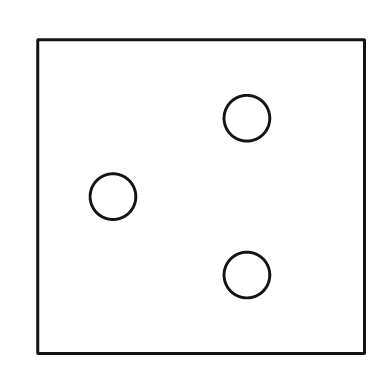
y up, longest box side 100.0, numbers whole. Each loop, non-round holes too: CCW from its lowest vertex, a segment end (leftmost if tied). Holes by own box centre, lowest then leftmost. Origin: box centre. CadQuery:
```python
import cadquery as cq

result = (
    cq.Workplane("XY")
    .moveTo(-50.0, -48.0)
    .lineTo(50.0, -48.0)
    .lineTo(50.0, 48.0)
    .lineTo(-50.0, 48.0)
    .close()
    .moveTo(14.0, -24.0)
    .circle(7.0)
    .moveTo(-27.0, 0.0)
    .circle(7.0)
    .moveTo(14.0, 24.0)
    .circle(7.0)
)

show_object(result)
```